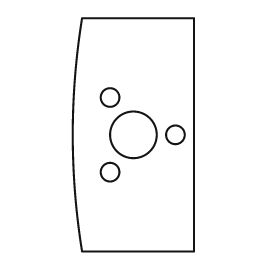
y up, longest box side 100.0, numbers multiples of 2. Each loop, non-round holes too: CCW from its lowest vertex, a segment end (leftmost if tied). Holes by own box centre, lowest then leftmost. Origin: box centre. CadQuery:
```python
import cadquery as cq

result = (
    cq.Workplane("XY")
    .moveTo(-22.0, -50.0)
    .lineTo(26.0, -50.0)
    .lineTo(26.0, 50.0)
    .lineTo(-22.0, 50.0)
    .threePointArc((-26.0, 0.0), (-22.0, -50.0))
    .close()
    .moveTo(-10.0, -16.0)
    .circle(4.0)
    .moveTo(0.0, 0.0)
    .circle(10.0)
    .moveTo(18.0, 0.0)
    .circle(4.0)
    .moveTo(-10.0, 16.0)
    .circle(4.0)
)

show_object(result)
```